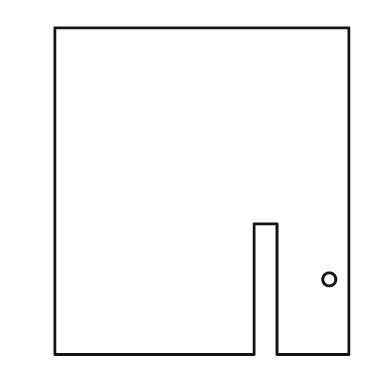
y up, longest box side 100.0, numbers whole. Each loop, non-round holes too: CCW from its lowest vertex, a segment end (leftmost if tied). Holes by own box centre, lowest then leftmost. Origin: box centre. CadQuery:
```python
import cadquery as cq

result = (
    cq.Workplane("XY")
    .moveTo(-45.0, -50.0)
    .lineTo(16.0, -50.0)
    .lineTo(16.0, -10.0)
    .lineTo(23.0, -10.0)
    .lineTo(23.0, -50.0)
    .lineTo(45.0, -50.0)
    .lineTo(45.0, 50.0)
    .lineTo(-45.0, 50.0)
    .close()
    .moveTo(39.0, -27.0)
    .circle(2.0)
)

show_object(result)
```